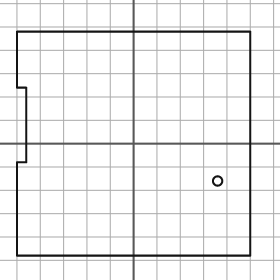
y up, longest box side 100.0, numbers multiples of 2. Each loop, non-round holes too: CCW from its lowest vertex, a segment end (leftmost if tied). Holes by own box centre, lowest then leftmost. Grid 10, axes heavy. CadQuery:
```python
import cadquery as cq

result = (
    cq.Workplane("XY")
    .moveTo(-50.0, -48.0)
    .lineTo(50.0, -48.0)
    .lineTo(50.0, 48.0)
    .lineTo(-50.0, 48.0)
    .lineTo(-50.0, 24.0)
    .lineTo(-46.0, 24.0)
    .lineTo(-46.0, -8.0)
    .lineTo(-50.0, -8.0)
    .close()
    .moveTo(36.0, -16.0)
    .circle(2.0)
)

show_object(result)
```